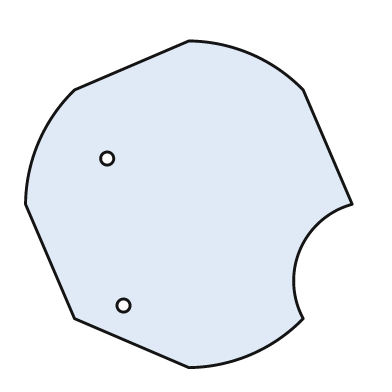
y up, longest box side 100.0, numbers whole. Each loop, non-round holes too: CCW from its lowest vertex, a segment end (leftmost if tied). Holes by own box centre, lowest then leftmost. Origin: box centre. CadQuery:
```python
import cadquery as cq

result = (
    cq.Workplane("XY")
    .moveTo(0.0, -50.0)
    .threePointArc((19.0, -46.0), (35.0, -35.0))
    .threePointArc((34.0, -14.0), (50.0, 0.0))
    .lineTo(35.0, 35.0)
    .threePointArc((19.0, 46.0), (0.0, 50.0))
    .lineTo(-35.0, 35.0)
    .threePointArc((-46.0, 19.0), (-50.0, 0.0))
    .lineTo(-35.0, -35.0)
    .close()
    .moveTo(-20.0, -31.0)
    .circle(2.0)
    .moveTo(-25.0, 14.0)
    .circle(2.0)
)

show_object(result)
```